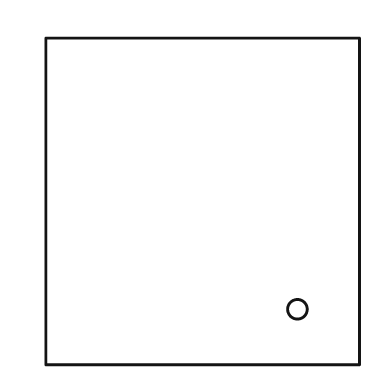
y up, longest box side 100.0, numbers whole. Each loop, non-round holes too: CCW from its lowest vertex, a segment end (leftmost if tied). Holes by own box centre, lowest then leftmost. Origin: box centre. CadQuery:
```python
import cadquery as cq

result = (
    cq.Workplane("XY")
    .moveTo(-48.0, -50.0)
    .lineTo(48.0, -50.0)
    .lineTo(48.0, 50.0)
    .lineTo(-48.0, 50.0)
    .close()
    .moveTo(29.0, -33.0)
    .circle(3.0)
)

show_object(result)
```